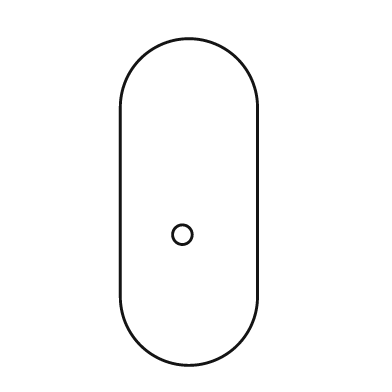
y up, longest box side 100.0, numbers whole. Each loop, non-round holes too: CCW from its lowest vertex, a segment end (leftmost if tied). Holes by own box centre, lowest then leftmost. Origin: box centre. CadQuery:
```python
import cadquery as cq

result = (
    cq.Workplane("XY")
    .moveTo(-21.0, -29.0)
    .threePointArc((0.0, -50.0), (21.0, -29.0))
    .lineTo(21.0, 29.0)
    .threePointArc((0.0, 50.0), (-21.0, 29.0))
    .close()
    .moveTo(-2.0, -10.0)
    .circle(3.0)
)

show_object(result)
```